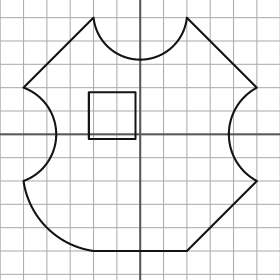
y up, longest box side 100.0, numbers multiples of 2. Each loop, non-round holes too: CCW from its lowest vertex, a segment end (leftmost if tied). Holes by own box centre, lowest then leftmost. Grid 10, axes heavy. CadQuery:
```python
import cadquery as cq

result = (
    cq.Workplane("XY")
    .moveTo(-20.0, -50.0)
    .lineTo(20.0, -50.0)
    .lineTo(50.0, -20.0)
    .threePointArc((38.0, 0.0), (50.0, 20.0))
    .lineTo(20.0, 50.0)
    .threePointArc((0.0, 32.0), (-20.0, 50.0))
    .lineTo(-50.0, 20.0)
    .threePointArc((-36.0, 0.0), (-50.0, -20.0))
    .threePointArc((-40.0, -40.0), (-20.0, -50.0))
    .close()
    .moveTo(-22.0, -2.0)
    .lineTo(-2.0, -2.0)
    .lineTo(-2.0, 18.0)
    .lineTo(-22.0, 18.0)
    .close()
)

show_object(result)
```